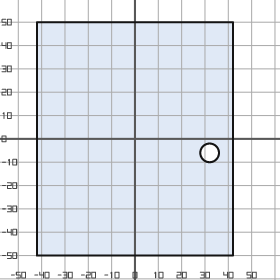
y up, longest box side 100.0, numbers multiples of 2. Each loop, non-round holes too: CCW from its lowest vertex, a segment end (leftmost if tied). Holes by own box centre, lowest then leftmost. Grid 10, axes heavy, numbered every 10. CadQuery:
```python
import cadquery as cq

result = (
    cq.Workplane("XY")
    .moveTo(-42.0, -50.0)
    .lineTo(42.0, -50.0)
    .lineTo(42.0, 50.0)
    .lineTo(-42.0, 50.0)
    .close()
    .moveTo(32.0, -6.0)
    .circle(4.0)
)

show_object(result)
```